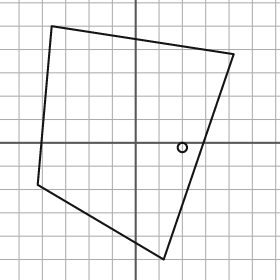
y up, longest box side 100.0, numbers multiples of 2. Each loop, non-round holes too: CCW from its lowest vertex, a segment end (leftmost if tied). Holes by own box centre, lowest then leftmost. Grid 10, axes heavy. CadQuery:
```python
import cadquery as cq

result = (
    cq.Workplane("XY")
    .moveTo(12.0, -50.0)
    .lineTo(42.0, 38.0)
    .lineTo(-36.0, 50.0)
    .lineTo(-42.0, -18.0)
    .close()
    .moveTo(20.0, -2.0)
    .circle(2.0)
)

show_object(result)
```